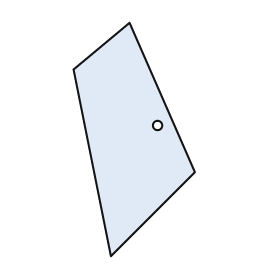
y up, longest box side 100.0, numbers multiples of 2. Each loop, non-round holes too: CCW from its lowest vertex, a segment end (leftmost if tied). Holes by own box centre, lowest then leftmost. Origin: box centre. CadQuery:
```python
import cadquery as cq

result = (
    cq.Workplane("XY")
    .moveTo(-10.0, -50.0)
    .lineTo(26.0, -14.0)
    .lineTo(-2.0, 50.0)
    .lineTo(-26.0, 30.0)
    .close()
    .moveTo(10.0, 6.0)
    .circle(2.0)
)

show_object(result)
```